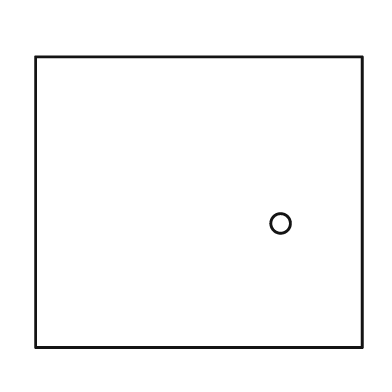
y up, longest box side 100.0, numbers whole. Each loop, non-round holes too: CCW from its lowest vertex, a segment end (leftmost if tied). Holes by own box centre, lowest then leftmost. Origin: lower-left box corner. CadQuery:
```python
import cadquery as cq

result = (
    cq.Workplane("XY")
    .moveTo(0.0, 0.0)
    .lineTo(100.0, 0.0)
    .lineTo(100.0, 89.0)
    .lineTo(0.0, 89.0)
    .close()
    .moveTo(75.0, 38.0)
    .circle(3.0)
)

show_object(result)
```